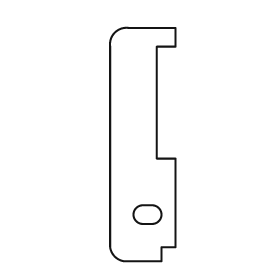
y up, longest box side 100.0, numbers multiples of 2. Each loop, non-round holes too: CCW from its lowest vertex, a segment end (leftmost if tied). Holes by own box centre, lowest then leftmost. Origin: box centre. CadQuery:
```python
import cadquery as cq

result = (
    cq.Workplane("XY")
    .moveTo(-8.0, -50.0)
    .lineTo(8.0, -50.0)
    .lineTo(8.0, -44.0)
    .lineTo(14.0, -44.0)
    .lineTo(14.0, -6.0)
    .lineTo(6.0, -6.0)
    .lineTo(6.0, 42.0)
    .lineTo(14.0, 42.0)
    .lineTo(14.0, 50.0)
    .lineTo(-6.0, 50.0)
    .threePointArc((-12.0, 48.0), (-14.0, 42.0))
    .lineTo(-14.0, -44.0)
    .threePointArc((-12.0, -48.0), (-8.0, -50.0))
    .close()
    .moveTo(0.0, -34.0)
    .lineTo(4.0, -34.0)
    .threePointArc((8.0, -30.0), (4.0, -26.0))
    .lineTo(0.0, -26.0)
    .threePointArc((-4.0, -30.0), (0.0, -34.0))
    .close()
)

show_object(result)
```